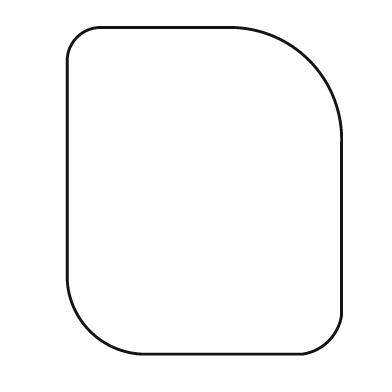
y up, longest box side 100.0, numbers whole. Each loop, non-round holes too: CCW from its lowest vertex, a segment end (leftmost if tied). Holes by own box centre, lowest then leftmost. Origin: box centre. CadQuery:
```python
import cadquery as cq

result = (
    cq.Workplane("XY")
    .moveTo(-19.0, -50.0)
    .lineTo(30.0, -50.0)
    .threePointArc((38.0, -46.0), (42.0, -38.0))
    .lineTo(42.0, 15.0)
    .threePointArc((32.0, 40.0), (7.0, 50.0))
    .lineTo(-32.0, 50.0)
    .threePointArc((-39.0, 47.0), (-42.0, 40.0))
    .lineTo(-42.0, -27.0)
    .threePointArc((-35.0, -43.0), (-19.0, -50.0))
    .close()
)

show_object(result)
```